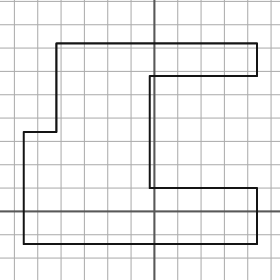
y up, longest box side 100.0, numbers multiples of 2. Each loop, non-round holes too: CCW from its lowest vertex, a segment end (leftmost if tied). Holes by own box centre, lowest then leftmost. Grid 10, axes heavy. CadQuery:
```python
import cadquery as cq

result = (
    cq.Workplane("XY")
    .moveTo(-56.0, -14.0)
    .lineTo(44.0, -14.0)
    .lineTo(44.0, 10.0)
    .lineTo(-2.0, 10.0)
    .lineTo(-2.0, 58.0)
    .lineTo(44.0, 58.0)
    .lineTo(44.0, 72.0)
    .lineTo(-42.0, 72.0)
    .lineTo(-42.0, 34.0)
    .lineTo(-56.0, 34.0)
    .close()
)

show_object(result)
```